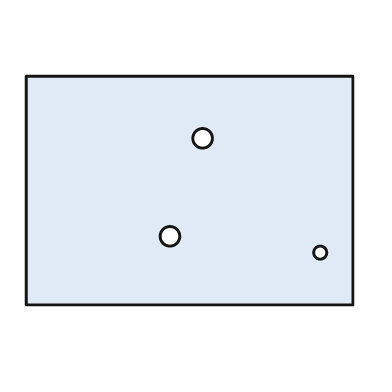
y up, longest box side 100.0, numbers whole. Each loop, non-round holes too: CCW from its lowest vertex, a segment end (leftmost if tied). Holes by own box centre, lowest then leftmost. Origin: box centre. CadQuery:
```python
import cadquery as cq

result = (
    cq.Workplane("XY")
    .moveTo(-50.0, -35.0)
    .lineTo(50.0, -35.0)
    .lineTo(50.0, 35.0)
    .lineTo(-50.0, 35.0)
    .close()
    .moveTo(40.0, -19.0)
    .circle(2.0)
    .moveTo(-6.0, -14.0)
    .circle(3.0)
    .moveTo(4.0, 16.0)
    .circle(3.0)
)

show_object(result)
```